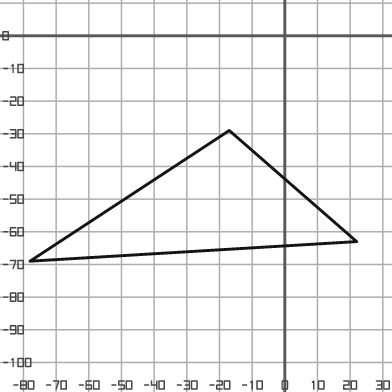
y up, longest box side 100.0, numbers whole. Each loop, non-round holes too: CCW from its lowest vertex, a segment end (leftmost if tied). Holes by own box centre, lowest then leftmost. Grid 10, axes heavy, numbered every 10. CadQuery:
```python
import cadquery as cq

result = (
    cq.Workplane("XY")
    .moveTo(-78.0, -69.0)
    .lineTo(22.0, -63.0)
    .lineTo(-17.0, -29.0)
    .close()
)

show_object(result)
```